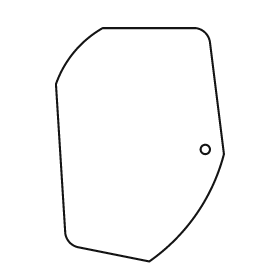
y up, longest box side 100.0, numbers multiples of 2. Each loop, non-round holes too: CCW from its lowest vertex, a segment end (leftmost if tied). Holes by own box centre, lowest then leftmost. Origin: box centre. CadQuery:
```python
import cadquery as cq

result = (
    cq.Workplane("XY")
    .moveTo(4.0, -50.0)
    .threePointArc((24.0, -30.0), (36.0, -4.0))
    .lineTo(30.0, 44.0)
    .threePointArc((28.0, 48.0), (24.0, 50.0))
    .lineTo(-16.0, 50.0)
    .threePointArc((-28.0, 40.0), (-36.0, 26.0))
    .lineTo(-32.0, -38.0)
    .threePointArc((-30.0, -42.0), (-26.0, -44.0))
    .close()
    .moveTo(28.0, -2.0)
    .circle(2.0)
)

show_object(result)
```